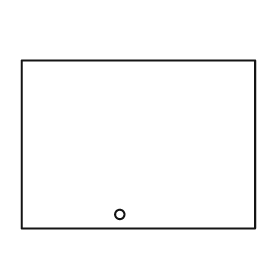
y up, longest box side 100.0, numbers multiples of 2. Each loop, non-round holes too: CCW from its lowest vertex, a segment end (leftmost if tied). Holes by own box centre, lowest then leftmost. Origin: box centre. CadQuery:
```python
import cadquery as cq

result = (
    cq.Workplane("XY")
    .moveTo(-50.0, -36.0)
    .lineTo(50.0, -36.0)
    .lineTo(50.0, 36.0)
    .lineTo(-50.0, 36.0)
    .close()
    .moveTo(-8.0, -30.0)
    .circle(2.0)
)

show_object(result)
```